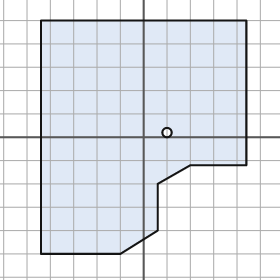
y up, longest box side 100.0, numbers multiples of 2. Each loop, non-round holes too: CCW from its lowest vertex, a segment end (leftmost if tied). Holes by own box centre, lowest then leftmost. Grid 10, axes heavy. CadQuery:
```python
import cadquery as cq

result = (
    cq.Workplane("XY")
    .moveTo(-44.0, -50.0)
    .lineTo(-10.0, -50.0)
    .lineTo(6.0, -40.0)
    .lineTo(6.0, -20.0)
    .lineTo(20.0, -12.0)
    .lineTo(44.0, -12.0)
    .lineTo(44.0, 50.0)
    .lineTo(-44.0, 50.0)
    .close()
    .moveTo(10.0, 2.0)
    .circle(2.0)
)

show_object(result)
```